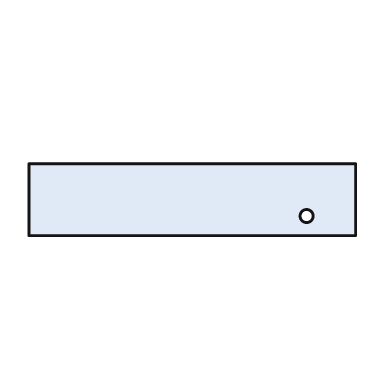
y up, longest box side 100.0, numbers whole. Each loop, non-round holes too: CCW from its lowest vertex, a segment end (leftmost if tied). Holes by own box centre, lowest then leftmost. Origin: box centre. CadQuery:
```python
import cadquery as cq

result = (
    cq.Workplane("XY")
    .moveTo(-50.0, -11.0)
    .lineTo(50.0, -11.0)
    .lineTo(50.0, 11.0)
    .lineTo(-50.0, 11.0)
    .close()
    .moveTo(35.0, -5.0)
    .circle(2.0)
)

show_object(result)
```